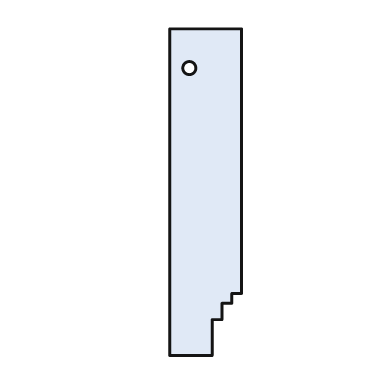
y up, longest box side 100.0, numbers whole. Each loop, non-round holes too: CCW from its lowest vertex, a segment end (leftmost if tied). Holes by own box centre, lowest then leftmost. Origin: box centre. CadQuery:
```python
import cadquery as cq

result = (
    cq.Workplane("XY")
    .moveTo(-11.0, -50.0)
    .lineTo(2.0, -50.0)
    .lineTo(2.0, -39.0)
    .lineTo(5.0, -39.0)
    .lineTo(5.0, -34.0)
    .lineTo(8.0, -34.0)
    .lineTo(8.0, -31.0)
    .lineTo(11.0, -31.0)
    .lineTo(11.0, 50.0)
    .lineTo(-11.0, 50.0)
    .close()
    .moveTo(-5.0, 38.0)
    .circle(2.0)
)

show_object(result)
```